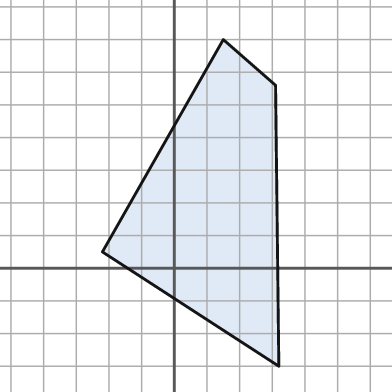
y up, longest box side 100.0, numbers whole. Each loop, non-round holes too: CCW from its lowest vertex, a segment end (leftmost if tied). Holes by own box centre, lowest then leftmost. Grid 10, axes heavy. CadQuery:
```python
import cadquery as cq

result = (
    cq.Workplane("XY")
    .moveTo(32.0, -30.0)
    .lineTo(31.0, 56.0)
    .lineTo(15.0, 70.0)
    .lineTo(-22.0, 5.0)
    .close()
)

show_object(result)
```